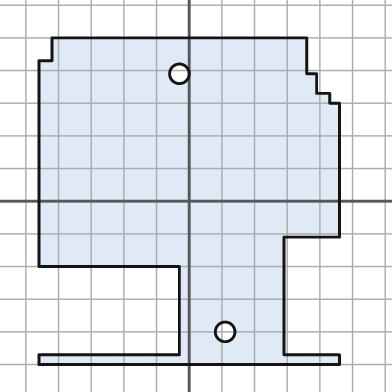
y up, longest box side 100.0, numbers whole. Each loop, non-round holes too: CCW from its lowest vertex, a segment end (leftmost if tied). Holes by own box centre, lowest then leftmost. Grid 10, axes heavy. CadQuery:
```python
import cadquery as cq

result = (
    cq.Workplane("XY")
    .moveTo(-46.0, -50.0)
    .lineTo(46.0, -50.0)
    .lineTo(46.0, -47.0)
    .lineTo(29.0, -47.0)
    .lineTo(29.0, -11.0)
    .lineTo(46.0, -11.0)
    .lineTo(46.0, 30.0)
    .lineTo(43.0, 30.0)
    .lineTo(43.0, 33.0)
    .lineTo(39.0, 33.0)
    .lineTo(39.0, 39.0)
    .lineTo(36.0, 39.0)
    .lineTo(36.0, 50.0)
    .lineTo(-42.0, 50.0)
    .lineTo(-42.0, 43.0)
    .lineTo(-46.0, 43.0)
    .lineTo(-46.0, -20.0)
    .lineTo(-3.0, -20.0)
    .lineTo(-3.0, -47.0)
    .lineTo(-46.0, -47.0)
    .close()
    .moveTo(11.0, -40.0)
    .circle(3.0)
    .moveTo(-3.0, 39.0)
    .circle(3.0)
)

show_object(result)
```